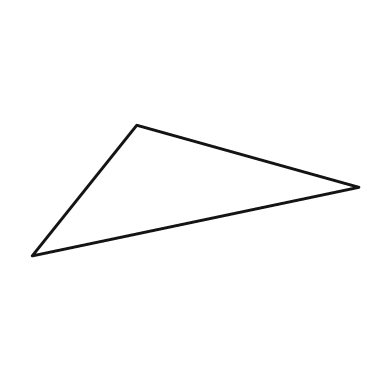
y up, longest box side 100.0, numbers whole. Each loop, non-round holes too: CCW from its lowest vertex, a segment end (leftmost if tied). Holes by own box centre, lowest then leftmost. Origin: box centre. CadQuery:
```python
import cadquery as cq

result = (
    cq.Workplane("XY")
    .moveTo(-50.0, -20.0)
    .lineTo(50.0, 1.0)
    .lineTo(-18.0, 20.0)
    .close()
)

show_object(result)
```